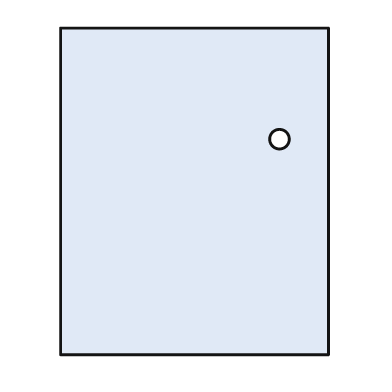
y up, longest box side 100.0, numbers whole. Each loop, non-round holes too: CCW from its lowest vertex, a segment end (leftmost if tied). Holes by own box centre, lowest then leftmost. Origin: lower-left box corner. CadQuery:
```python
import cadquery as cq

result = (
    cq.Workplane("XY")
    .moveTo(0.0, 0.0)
    .lineTo(82.0, 0.0)
    .lineTo(82.0, 100.0)
    .lineTo(0.0, 100.0)
    .close()
    .moveTo(67.0, 66.0)
    .circle(3.0)
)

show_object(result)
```